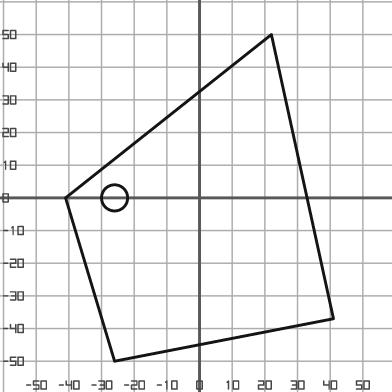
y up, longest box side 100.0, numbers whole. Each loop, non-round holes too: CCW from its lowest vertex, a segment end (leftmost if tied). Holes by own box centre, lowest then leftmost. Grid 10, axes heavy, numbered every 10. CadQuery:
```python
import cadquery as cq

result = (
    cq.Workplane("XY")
    .moveTo(-26.0, -50.0)
    .lineTo(41.0, -37.0)
    .lineTo(22.0, 50.0)
    .lineTo(-41.0, 0.0)
    .close()
    .moveTo(-26.0, 0.0)
    .circle(4.0)
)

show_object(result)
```